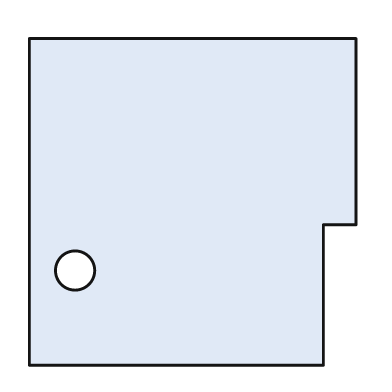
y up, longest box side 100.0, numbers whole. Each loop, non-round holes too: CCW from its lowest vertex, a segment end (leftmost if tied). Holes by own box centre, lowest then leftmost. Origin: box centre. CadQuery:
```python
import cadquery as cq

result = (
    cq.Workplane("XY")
    .moveTo(-50.0, -50.0)
    .lineTo(40.0, -50.0)
    .lineTo(40.0, -7.0)
    .lineTo(50.0, -7.0)
    .lineTo(50.0, 50.0)
    .lineTo(-50.0, 50.0)
    .close()
    .moveTo(-36.0, -21.0)
    .circle(6.0)
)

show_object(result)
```